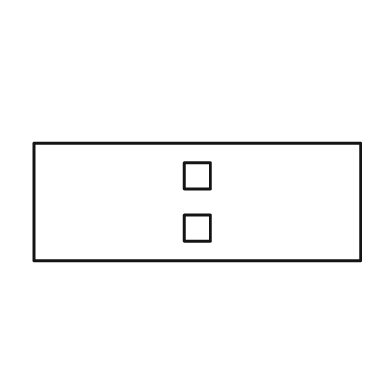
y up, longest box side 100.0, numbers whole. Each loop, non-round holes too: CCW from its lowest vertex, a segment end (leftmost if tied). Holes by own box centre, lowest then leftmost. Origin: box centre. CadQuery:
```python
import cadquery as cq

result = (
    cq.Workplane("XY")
    .moveTo(-50.0, -18.0)
    .lineTo(50.0, -18.0)
    .lineTo(50.0, 18.0)
    .lineTo(-50.0, 18.0)
    .close()
    .moveTo(-4.0, -12.0)
    .lineTo(4.0, -12.0)
    .lineTo(4.0, -4.0)
    .lineTo(-4.0, -4.0)
    .close()
    .moveTo(-4.0, 4.0)
    .lineTo(4.0, 4.0)
    .lineTo(4.0, 12.0)
    .lineTo(-4.0, 12.0)
    .close()
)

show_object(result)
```